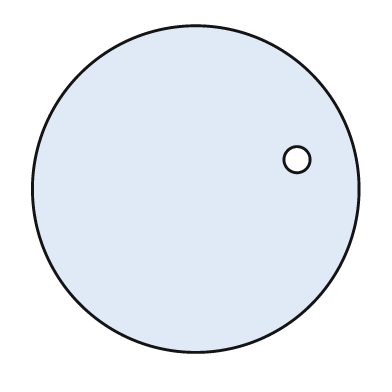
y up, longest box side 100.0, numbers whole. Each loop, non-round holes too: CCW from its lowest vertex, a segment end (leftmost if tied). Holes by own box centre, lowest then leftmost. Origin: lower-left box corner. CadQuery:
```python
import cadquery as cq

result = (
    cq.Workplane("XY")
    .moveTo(50.0, 50.0)
    .circle(50.0)
    .moveTo(81.0, 59.0)
    .circle(4.0)
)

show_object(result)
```